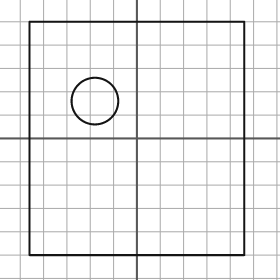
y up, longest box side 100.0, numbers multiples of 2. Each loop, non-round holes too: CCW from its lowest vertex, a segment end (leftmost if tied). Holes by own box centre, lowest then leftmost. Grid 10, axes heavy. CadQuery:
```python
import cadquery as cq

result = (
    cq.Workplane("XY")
    .moveTo(-46.0, -50.0)
    .lineTo(46.0, -50.0)
    .lineTo(46.0, 50.0)
    .lineTo(-46.0, 50.0)
    .close()
    .moveTo(-18.0, 16.0)
    .circle(10.0)
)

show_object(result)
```